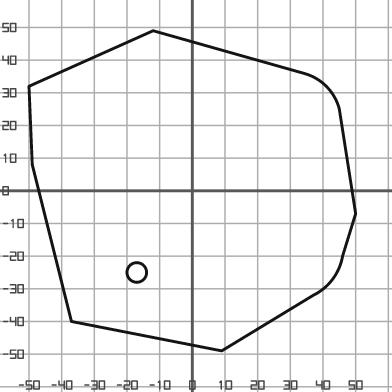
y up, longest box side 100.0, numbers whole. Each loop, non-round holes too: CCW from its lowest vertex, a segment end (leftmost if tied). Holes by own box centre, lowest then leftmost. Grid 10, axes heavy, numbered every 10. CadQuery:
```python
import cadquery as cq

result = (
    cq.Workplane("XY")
    .moveTo(9.0, -49.0)
    .lineTo(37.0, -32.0)
    .threePointArc((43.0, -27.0), (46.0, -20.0))
    .lineTo(50.0, -7.0)
    .lineTo(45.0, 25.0)
    .threePointArc((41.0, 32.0), (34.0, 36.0))
    .lineTo(-12.0, 49.0)
    .lineTo(-50.0, 32.0)
    .lineTo(-49.0, 8.0)
    .lineTo(-37.0, -40.0)
    .close()
    .moveTo(-17.0, -25.0)
    .circle(3.0)
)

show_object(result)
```